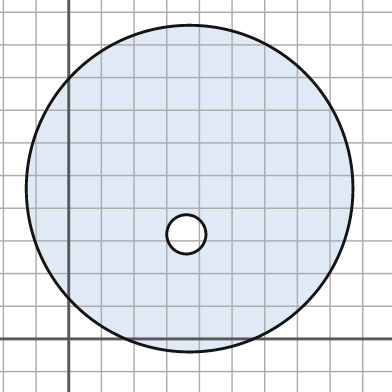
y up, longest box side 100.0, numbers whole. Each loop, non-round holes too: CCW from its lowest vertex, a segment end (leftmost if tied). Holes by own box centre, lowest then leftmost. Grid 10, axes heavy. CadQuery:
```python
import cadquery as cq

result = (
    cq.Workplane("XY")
    .moveTo(37.0, 46.0)
    .circle(50.0)
    .moveTo(36.0, 32.0)
    .circle(6.0)
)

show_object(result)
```